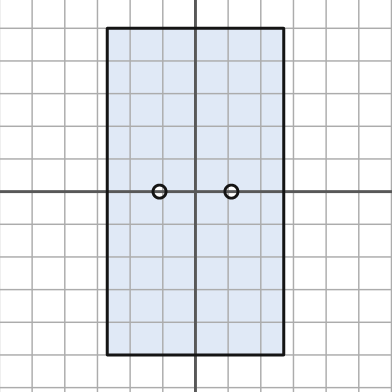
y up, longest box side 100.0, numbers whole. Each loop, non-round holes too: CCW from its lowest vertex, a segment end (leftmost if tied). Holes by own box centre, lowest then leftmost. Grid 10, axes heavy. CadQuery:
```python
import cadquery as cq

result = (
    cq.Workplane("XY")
    .moveTo(-27.0, -50.0)
    .lineTo(27.0, -50.0)
    .lineTo(27.0, 50.0)
    .lineTo(-27.0, 50.0)
    .close()
    .moveTo(-11.0, 0.0)
    .circle(2.0)
    .moveTo(11.0, 0.0)
    .circle(2.0)
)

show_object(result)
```